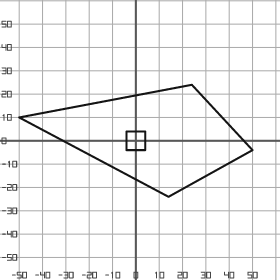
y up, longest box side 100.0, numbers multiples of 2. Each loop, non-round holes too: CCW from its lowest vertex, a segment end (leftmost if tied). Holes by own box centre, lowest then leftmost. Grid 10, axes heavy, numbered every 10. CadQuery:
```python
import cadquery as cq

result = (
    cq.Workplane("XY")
    .moveTo(14.0, -24.0)
    .lineTo(50.0, -4.0)
    .lineTo(24.0, 24.0)
    .lineTo(-50.0, 10.0)
    .close()
    .moveTo(-4.0, -4.0)
    .lineTo(4.0, -4.0)
    .lineTo(4.0, 4.0)
    .lineTo(-4.0, 4.0)
    .close()
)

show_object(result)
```